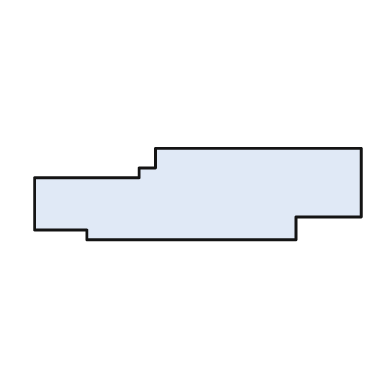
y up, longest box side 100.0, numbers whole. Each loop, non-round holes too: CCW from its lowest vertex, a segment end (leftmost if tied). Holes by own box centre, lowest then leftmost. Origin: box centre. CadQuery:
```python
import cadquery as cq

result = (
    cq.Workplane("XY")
    .moveTo(-34.0, -14.0)
    .lineTo(30.0, -14.0)
    .lineTo(30.0, -7.0)
    .lineTo(50.0, -7.0)
    .lineTo(50.0, 14.0)
    .lineTo(-13.0, 14.0)
    .lineTo(-13.0, 8.0)
    .lineTo(-18.0, 8.0)
    .lineTo(-18.0, 5.0)
    .lineTo(-50.0, 5.0)
    .lineTo(-50.0, -11.0)
    .lineTo(-34.0, -11.0)
    .close()
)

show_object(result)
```